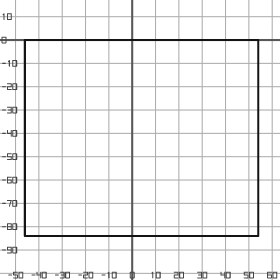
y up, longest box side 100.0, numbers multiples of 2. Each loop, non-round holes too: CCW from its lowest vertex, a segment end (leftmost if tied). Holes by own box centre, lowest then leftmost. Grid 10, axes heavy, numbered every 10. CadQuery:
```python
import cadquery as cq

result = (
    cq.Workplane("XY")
    .moveTo(-46.0, -84.0)
    .lineTo(54.0, -84.0)
    .lineTo(54.0, 0.0)
    .lineTo(-46.0, 0.0)
    .close()
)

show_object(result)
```